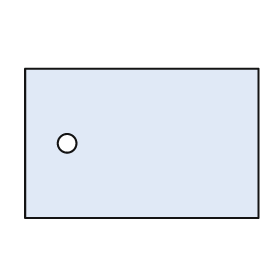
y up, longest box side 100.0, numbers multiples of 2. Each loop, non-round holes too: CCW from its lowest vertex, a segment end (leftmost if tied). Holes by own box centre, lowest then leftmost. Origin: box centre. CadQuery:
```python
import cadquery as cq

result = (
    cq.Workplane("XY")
    .moveTo(-50.0, -32.0)
    .lineTo(50.0, -32.0)
    .lineTo(50.0, 32.0)
    .lineTo(-50.0, 32.0)
    .close()
    .moveTo(-32.0, 0.0)
    .circle(4.0)
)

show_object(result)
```